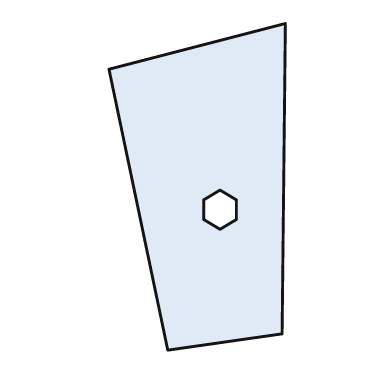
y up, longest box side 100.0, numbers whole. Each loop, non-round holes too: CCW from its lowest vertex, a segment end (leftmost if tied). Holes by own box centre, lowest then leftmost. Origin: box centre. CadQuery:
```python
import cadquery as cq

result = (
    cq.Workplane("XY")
    .moveTo(-9.0, -50.0)
    .lineTo(26.0, -45.0)
    .lineTo(27.0, 50.0)
    .lineTo(-27.0, 36.0)
    .close()
    .moveTo(7.0, -13.0)
    .lineTo(12.0, -10.0)
    .lineTo(12.0, -4.0)
    .lineTo(7.0, -1.0)
    .lineTo(2.0, -4.0)
    .lineTo(2.0, -10.0)
    .close()
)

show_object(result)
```